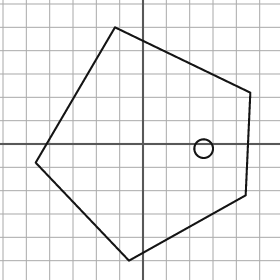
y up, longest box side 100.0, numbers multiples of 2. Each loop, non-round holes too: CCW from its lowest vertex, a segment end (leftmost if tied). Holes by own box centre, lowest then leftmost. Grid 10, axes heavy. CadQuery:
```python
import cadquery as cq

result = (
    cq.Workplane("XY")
    .moveTo(-6.0, -50.0)
    .lineTo(44.0, -22.0)
    .lineTo(46.0, 22.0)
    .lineTo(-12.0, 50.0)
    .lineTo(-46.0, -8.0)
    .close()
    .moveTo(26.0, -2.0)
    .circle(4.0)
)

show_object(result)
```